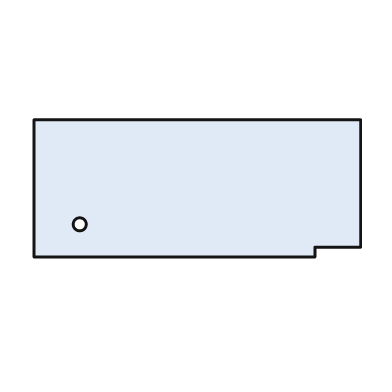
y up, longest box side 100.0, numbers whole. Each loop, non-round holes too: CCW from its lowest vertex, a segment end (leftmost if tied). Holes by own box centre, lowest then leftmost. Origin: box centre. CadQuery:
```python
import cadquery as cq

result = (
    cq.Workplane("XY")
    .moveTo(-50.0, -21.0)
    .lineTo(36.0, -21.0)
    .lineTo(36.0, -18.0)
    .lineTo(50.0, -18.0)
    .lineTo(50.0, 21.0)
    .lineTo(-50.0, 21.0)
    .close()
    .moveTo(-36.0, -11.0)
    .circle(2.0)
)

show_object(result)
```